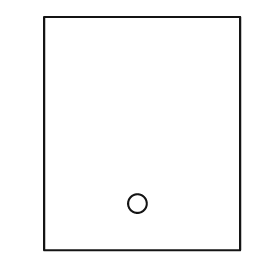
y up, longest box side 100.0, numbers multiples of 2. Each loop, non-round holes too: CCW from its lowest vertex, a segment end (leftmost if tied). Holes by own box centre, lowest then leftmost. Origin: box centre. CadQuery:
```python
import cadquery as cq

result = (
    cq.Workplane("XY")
    .moveTo(-42.0, -50.0)
    .lineTo(42.0, -50.0)
    .lineTo(42.0, 50.0)
    .lineTo(-42.0, 50.0)
    .close()
    .moveTo(-2.0, -30.0)
    .circle(4.0)
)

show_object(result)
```